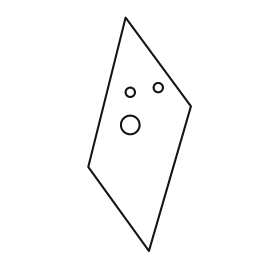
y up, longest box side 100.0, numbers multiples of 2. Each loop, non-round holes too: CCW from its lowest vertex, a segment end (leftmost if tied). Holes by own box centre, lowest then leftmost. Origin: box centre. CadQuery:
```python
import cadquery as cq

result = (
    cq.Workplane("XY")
    .moveTo(4.0, -50.0)
    .lineTo(22.0, 12.0)
    .lineTo(-6.0, 50.0)
    .lineTo(-22.0, -14.0)
    .close()
    .moveTo(-4.0, 4.0)
    .circle(4.0)
    .moveTo(-4.0, 18.0)
    .circle(2.0)
    .moveTo(8.0, 20.0)
    .circle(2.0)
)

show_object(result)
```